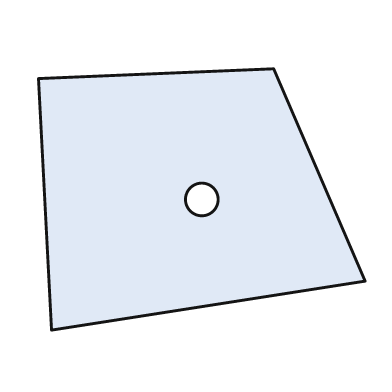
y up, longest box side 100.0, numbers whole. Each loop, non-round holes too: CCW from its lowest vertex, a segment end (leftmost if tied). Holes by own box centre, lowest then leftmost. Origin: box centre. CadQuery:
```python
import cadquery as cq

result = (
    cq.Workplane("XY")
    .moveTo(-46.0, -40.0)
    .lineTo(50.0, -25.0)
    .lineTo(22.0, 40.0)
    .lineTo(-50.0, 37.0)
    .close()
    .moveTo(0.0, 0.0)
    .circle(5.0)
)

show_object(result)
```